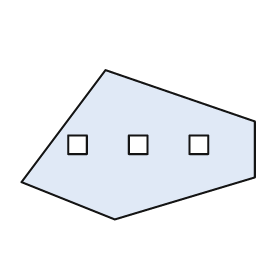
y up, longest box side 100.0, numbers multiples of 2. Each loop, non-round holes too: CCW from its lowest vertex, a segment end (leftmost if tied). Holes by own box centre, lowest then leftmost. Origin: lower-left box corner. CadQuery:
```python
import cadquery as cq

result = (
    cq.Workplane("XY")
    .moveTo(40.0, 0.0)
    .lineTo(100.0, 18.0)
    .lineTo(100.0, 42.0)
    .lineTo(36.0, 64.0)
    .lineTo(0.0, 16.0)
    .close()
    .moveTo(20.0, 28.0)
    .lineTo(28.0, 28.0)
    .lineTo(28.0, 36.0)
    .lineTo(20.0, 36.0)
    .close()
    .moveTo(46.0, 28.0)
    .lineTo(54.0, 28.0)
    .lineTo(54.0, 36.0)
    .lineTo(46.0, 36.0)
    .close()
    .moveTo(72.0, 28.0)
    .lineTo(80.0, 28.0)
    .lineTo(80.0, 36.0)
    .lineTo(72.0, 36.0)
    .close()
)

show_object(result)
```